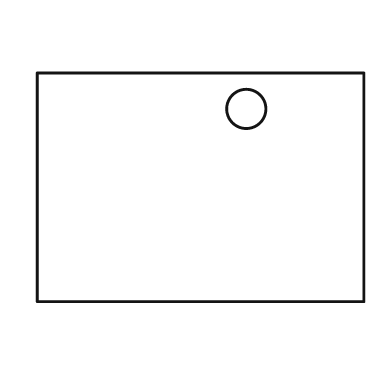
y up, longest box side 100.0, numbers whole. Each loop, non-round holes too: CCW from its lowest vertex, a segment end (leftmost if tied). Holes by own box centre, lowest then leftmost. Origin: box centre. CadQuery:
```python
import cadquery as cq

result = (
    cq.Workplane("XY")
    .moveTo(-50.0, -35.0)
    .lineTo(50.0, -35.0)
    .lineTo(50.0, 35.0)
    .lineTo(-50.0, 35.0)
    .close()
    .moveTo(14.0, 24.0)
    .circle(6.0)
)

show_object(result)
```